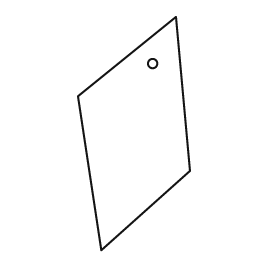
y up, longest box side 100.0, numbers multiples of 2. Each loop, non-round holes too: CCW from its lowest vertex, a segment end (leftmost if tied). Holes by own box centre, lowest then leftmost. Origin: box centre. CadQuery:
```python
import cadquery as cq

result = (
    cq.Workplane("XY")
    .moveTo(-14.0, -50.0)
    .lineTo(24.0, -16.0)
    .lineTo(18.0, 50.0)
    .lineTo(-24.0, 16.0)
    .close()
    .moveTo(8.0, 30.0)
    .circle(2.0)
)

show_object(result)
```